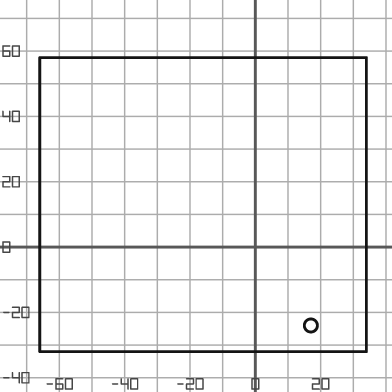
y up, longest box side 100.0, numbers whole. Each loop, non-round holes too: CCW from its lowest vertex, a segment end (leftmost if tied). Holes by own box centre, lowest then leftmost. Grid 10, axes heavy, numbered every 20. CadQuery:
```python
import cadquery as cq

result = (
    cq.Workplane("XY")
    .moveTo(-66.0, -32.0)
    .lineTo(34.0, -32.0)
    .lineTo(34.0, 58.0)
    .lineTo(-66.0, 58.0)
    .close()
    .moveTo(17.0, -24.0)
    .circle(2.0)
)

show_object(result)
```